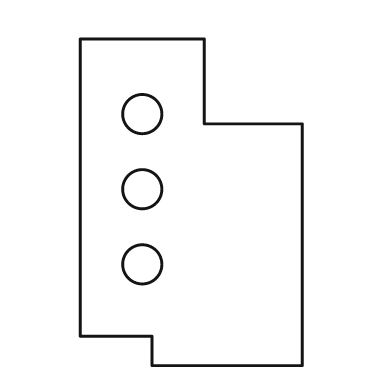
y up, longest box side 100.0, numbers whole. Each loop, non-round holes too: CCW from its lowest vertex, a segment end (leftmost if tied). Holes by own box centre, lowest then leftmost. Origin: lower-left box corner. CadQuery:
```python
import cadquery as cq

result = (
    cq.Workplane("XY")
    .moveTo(22.0, 0.0)
    .lineTo(68.0, 0.0)
    .lineTo(68.0, 74.0)
    .lineTo(38.0, 74.0)
    .lineTo(38.0, 100.0)
    .lineTo(0.0, 100.0)
    .lineTo(0.0, 9.0)
    .lineTo(22.0, 9.0)
    .close()
    .moveTo(19.0, 31.0)
    .circle(6.0)
    .moveTo(19.0, 54.0)
    .circle(6.0)
    .moveTo(19.0, 77.0)
    .circle(6.0)
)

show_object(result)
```